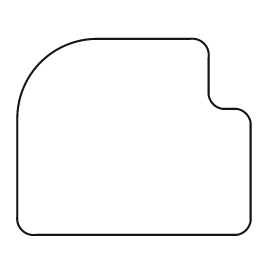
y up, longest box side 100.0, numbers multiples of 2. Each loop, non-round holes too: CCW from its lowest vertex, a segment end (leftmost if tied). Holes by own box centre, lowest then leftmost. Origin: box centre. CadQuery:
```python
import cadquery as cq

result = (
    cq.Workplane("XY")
    .moveTo(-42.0, -42.0)
    .lineTo(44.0, -42.0)
    .threePointArc((48.0, -40.0), (50.0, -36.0))
    .lineTo(50.0, 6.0)
    .threePointArc((48.0, 10.0), (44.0, 12.0))
    .lineTo(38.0, 12.0)
    .threePointArc((34.0, 14.0), (32.0, 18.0))
    .lineTo(32.0, 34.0)
    .threePointArc((30.0, 40.0), (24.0, 42.0))
    .lineTo(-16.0, 42.0)
    .threePointArc((-40.0, 32.0), (-50.0, 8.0))
    .lineTo(-50.0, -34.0)
    .threePointArc((-48.0, -40.0), (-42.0, -42.0))
    .close()
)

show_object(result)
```